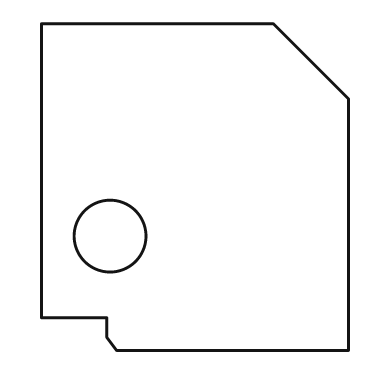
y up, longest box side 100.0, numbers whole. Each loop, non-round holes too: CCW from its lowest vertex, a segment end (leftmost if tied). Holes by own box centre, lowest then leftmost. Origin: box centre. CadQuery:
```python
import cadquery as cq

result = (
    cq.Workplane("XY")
    .moveTo(-24.0, -50.0)
    .lineTo(47.0, -50.0)
    .lineTo(47.0, 27.0)
    .lineTo(24.0, 50.0)
    .lineTo(-47.0, 50.0)
    .lineTo(-47.0, -40.0)
    .lineTo(-27.0, -40.0)
    .lineTo(-27.0, -46.0)
    .close()
    .moveTo(-26.0, -15.0)
    .circle(11.0)
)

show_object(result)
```